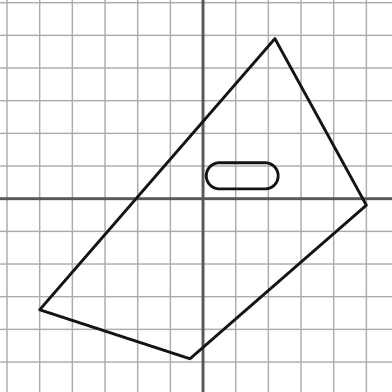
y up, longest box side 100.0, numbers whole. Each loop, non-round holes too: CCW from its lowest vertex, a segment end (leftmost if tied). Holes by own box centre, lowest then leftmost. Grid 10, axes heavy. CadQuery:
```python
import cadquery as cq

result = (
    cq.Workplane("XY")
    .moveTo(-4.0, -49.0)
    .lineTo(50.0, -2.0)
    .lineTo(22.0, 49.0)
    .lineTo(-50.0, -34.0)
    .close()
    .moveTo(5.0, 3.0)
    .lineTo(19.0, 3.0)
    .threePointArc((23.0, 7.0), (19.0, 11.0))
    .lineTo(5.0, 11.0)
    .threePointArc((1.0, 7.0), (5.0, 3.0))
    .close()
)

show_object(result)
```